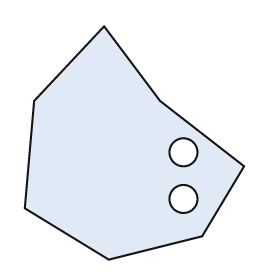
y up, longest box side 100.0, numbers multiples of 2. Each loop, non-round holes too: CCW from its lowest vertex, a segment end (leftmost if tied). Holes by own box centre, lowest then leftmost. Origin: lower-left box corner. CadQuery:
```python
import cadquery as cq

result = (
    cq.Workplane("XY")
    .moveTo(36.0, 0.0)
    .lineTo(76.0, 10.0)
    .lineTo(94.0, 40.0)
    .lineTo(58.0, 68.0)
    .lineTo(34.0, 100.0)
    .lineTo(4.0, 68.0)
    .lineTo(0.0, 22.0)
    .close()
    .moveTo(68.0, 26.0)
    .circle(6.0)
    .moveTo(68.0, 46.0)
    .circle(6.0)
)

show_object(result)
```